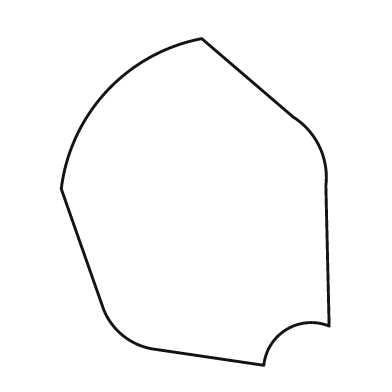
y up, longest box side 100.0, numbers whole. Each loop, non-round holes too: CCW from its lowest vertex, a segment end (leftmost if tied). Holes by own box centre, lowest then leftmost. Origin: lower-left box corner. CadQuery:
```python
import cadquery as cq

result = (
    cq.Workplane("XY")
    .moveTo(62.0, 0.0)
    .threePointArc((69.0, 11.0), (82.0, 12.0))
    .lineTo(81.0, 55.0)
    .threePointArc((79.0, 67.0), (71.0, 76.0))
    .lineTo(43.0, 100.0)
    .threePointArc((14.0, 84.0), (0.0, 54.0))
    .lineTo(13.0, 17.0)
    .threePointArc((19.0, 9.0), (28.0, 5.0))
    .close()
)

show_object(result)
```